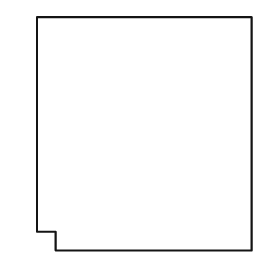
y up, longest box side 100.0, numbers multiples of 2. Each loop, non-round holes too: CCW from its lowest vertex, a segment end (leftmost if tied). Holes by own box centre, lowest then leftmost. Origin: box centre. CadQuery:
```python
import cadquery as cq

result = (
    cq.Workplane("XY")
    .moveTo(-38.0, -50.0)
    .lineTo(46.0, -50.0)
    .lineTo(46.0, 50.0)
    .lineTo(-46.0, 50.0)
    .lineTo(-46.0, -42.0)
    .lineTo(-38.0, -42.0)
    .close()
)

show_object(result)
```